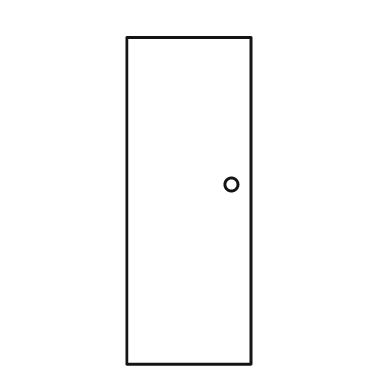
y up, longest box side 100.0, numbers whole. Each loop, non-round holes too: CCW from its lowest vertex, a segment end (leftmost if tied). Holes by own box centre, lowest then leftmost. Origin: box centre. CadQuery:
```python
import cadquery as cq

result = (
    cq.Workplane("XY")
    .moveTo(-19.0, -50.0)
    .lineTo(19.0, -50.0)
    .lineTo(19.0, 50.0)
    .lineTo(-19.0, 50.0)
    .close()
    .moveTo(13.0, 5.0)
    .circle(2.0)
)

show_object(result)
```